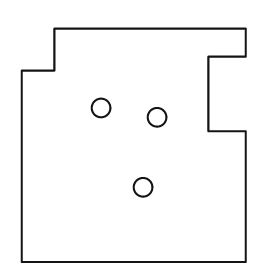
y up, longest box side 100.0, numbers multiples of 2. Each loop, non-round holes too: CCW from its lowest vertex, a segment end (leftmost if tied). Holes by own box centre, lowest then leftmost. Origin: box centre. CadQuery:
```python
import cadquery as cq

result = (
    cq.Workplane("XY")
    .moveTo(-48.0, -50.0)
    .lineTo(48.0, -50.0)
    .lineTo(48.0, 6.0)
    .lineTo(32.0, 6.0)
    .lineTo(32.0, 38.0)
    .lineTo(48.0, 38.0)
    .lineTo(48.0, 50.0)
    .lineTo(-34.0, 50.0)
    .lineTo(-34.0, 32.0)
    .lineTo(-48.0, 32.0)
    .close()
    .moveTo(4.0, -18.0)
    .circle(4.0)
    .moveTo(10.0, 12.0)
    .circle(4.0)
    .moveTo(-14.0, 16.0)
    .circle(4.0)
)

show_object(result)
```